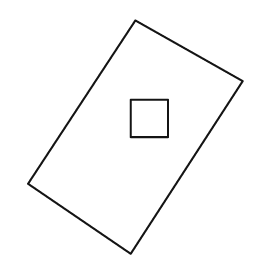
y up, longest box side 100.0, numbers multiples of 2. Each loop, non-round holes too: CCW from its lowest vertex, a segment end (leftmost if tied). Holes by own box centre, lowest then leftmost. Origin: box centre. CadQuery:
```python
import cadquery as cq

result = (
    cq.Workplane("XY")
    .moveTo(-2.0, -50.0)
    .lineTo(46.0, 24.0)
    .lineTo(0.0, 50.0)
    .lineTo(-46.0, -20.0)
    .close()
    .moveTo(-2.0, 0.0)
    .lineTo(14.0, 0.0)
    .lineTo(14.0, 16.0)
    .lineTo(-2.0, 16.0)
    .close()
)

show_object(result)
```